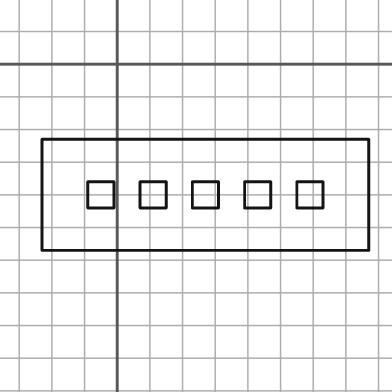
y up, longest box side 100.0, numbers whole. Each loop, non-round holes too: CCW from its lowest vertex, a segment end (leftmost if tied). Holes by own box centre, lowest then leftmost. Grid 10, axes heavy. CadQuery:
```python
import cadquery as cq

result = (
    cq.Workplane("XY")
    .moveTo(-23.0, -57.0)
    .lineTo(77.0, -57.0)
    .lineTo(77.0, -23.0)
    .lineTo(-23.0, -23.0)
    .close()
    .moveTo(-9.0, -44.0)
    .lineTo(-1.0, -44.0)
    .lineTo(-1.0, -36.0)
    .lineTo(-9.0, -36.0)
    .close()
    .moveTo(7.0, -44.0)
    .lineTo(15.0, -44.0)
    .lineTo(15.0, -36.0)
    .lineTo(7.0, -36.0)
    .close()
    .moveTo(23.0, -44.0)
    .lineTo(31.0, -44.0)
    .lineTo(31.0, -36.0)
    .lineTo(23.0, -36.0)
    .close()
    .moveTo(39.0, -44.0)
    .lineTo(47.0, -44.0)
    .lineTo(47.0, -36.0)
    .lineTo(39.0, -36.0)
    .close()
    .moveTo(55.0, -44.0)
    .lineTo(63.0, -44.0)
    .lineTo(63.0, -36.0)
    .lineTo(55.0, -36.0)
    .close()
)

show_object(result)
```